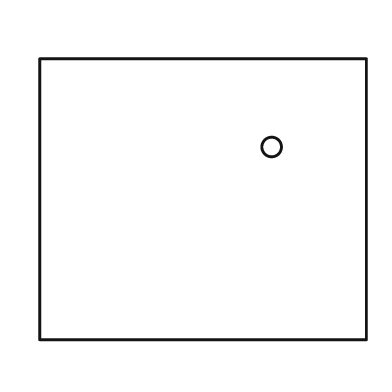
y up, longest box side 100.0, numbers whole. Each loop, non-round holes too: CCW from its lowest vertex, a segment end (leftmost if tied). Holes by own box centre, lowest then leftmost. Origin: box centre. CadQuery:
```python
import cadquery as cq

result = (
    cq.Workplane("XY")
    .moveTo(-50.0, -43.0)
    .lineTo(50.0, -43.0)
    .lineTo(50.0, 43.0)
    .lineTo(-50.0, 43.0)
    .close()
    .moveTo(21.0, 16.0)
    .circle(3.0)
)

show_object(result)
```